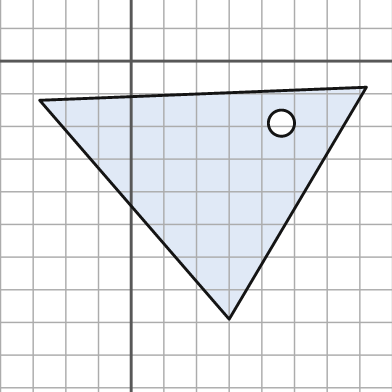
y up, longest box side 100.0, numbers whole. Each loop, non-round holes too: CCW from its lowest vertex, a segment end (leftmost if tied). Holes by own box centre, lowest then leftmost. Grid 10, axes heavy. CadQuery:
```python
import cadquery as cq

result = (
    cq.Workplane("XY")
    .moveTo(30.0, -79.0)
    .lineTo(72.0, -8.0)
    .lineTo(-28.0, -12.0)
    .close()
    .moveTo(46.0, -19.0)
    .circle(4.0)
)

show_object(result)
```